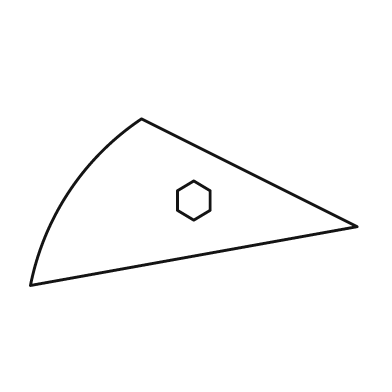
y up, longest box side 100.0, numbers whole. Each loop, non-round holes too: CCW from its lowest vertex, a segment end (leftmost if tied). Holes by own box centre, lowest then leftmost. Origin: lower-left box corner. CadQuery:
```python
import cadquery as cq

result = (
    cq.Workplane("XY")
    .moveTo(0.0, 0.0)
    .lineTo(100.0, 18.0)
    .lineTo(34.0, 51.0)
    .threePointArc((12.0, 29.0), (0.0, 0.0))
    .close()
    .moveTo(50.0, 20.0)
    .lineTo(55.0, 23.0)
    .lineTo(55.0, 29.0)
    .lineTo(50.0, 32.0)
    .lineTo(45.0, 29.0)
    .lineTo(45.0, 23.0)
    .close()
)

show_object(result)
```